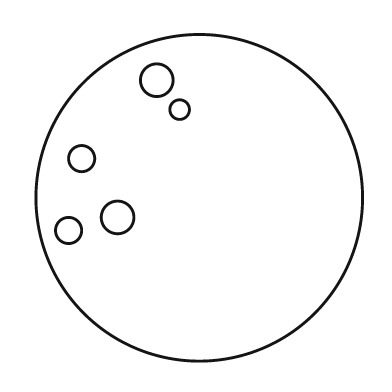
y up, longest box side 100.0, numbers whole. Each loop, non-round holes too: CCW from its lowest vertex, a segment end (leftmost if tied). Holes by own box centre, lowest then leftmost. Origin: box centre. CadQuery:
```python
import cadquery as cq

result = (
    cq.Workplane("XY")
    .moveTo(0.0, 0.0)
    .circle(50.0)
    .moveTo(-40.0, -10.0)
    .circle(4.0)
    .moveTo(-25.0, -6.0)
    .circle(5.0)
    .moveTo(-36.0, 12.0)
    .circle(4.0)
    .moveTo(-6.0, 27.0)
    .circle(3.0)
    .moveTo(-13.0, 36.0)
    .circle(5.0)
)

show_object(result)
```